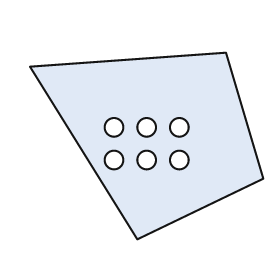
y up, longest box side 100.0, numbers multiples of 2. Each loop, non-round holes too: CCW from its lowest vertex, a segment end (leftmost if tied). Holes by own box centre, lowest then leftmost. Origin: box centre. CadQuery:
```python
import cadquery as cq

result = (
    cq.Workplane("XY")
    .moveTo(-4.0, -40.0)
    .lineTo(50.0, -14.0)
    .lineTo(34.0, 40.0)
    .lineTo(-50.0, 34.0)
    .close()
    .moveTo(-14.0, -6.0)
    .circle(4.0)
    .moveTo(0.0, -6.0)
    .circle(4.0)
    .moveTo(14.0, -6.0)
    .circle(4.0)
    .moveTo(-14.0, 8.0)
    .circle(4.0)
    .moveTo(0.0, 8.0)
    .circle(4.0)
    .moveTo(14.0, 8.0)
    .circle(4.0)
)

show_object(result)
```